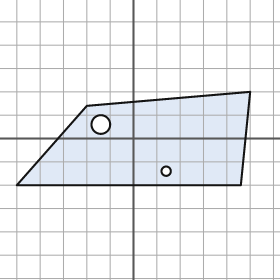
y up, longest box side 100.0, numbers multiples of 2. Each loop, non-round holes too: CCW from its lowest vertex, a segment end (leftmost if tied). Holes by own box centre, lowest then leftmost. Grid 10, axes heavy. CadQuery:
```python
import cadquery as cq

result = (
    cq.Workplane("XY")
    .moveTo(-50.0, -20.0)
    .lineTo(46.0, -20.0)
    .lineTo(50.0, 20.0)
    .lineTo(-20.0, 14.0)
    .close()
    .moveTo(14.0, -14.0)
    .circle(2.0)
    .moveTo(-14.0, 6.0)
    .circle(4.0)
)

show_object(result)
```